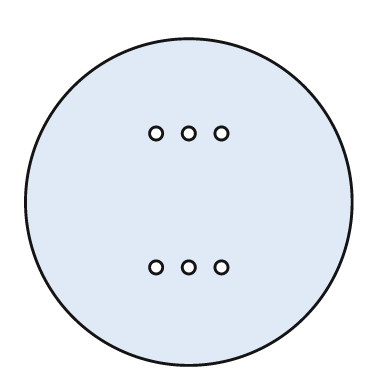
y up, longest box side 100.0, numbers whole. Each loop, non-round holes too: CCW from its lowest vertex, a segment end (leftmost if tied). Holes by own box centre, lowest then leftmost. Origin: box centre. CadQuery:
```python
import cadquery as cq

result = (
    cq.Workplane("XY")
    .moveTo(0.0, 0.0)
    .circle(50.0)
    .moveTo(-10.0, -20.0)
    .circle(2.0)
    .moveTo(0.0, -20.0)
    .circle(2.0)
    .moveTo(10.0, -20.0)
    .circle(2.0)
    .moveTo(-10.0, 21.0)
    .circle(2.0)
    .moveTo(0.0, 21.0)
    .circle(2.0)
    .moveTo(10.0, 21.0)
    .circle(2.0)
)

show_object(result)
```